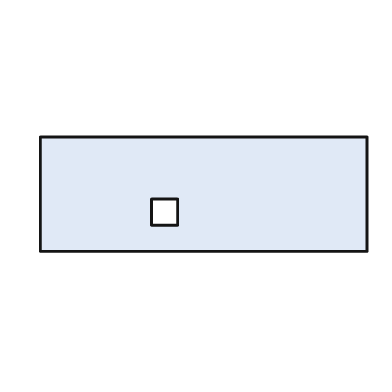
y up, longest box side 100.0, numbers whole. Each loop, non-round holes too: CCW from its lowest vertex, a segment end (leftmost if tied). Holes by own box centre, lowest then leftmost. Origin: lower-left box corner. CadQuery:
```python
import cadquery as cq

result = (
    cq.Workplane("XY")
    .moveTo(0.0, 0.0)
    .lineTo(100.0, 0.0)
    .lineTo(100.0, 35.0)
    .lineTo(0.0, 35.0)
    .close()
    .moveTo(34.0, 8.0)
    .lineTo(42.0, 8.0)
    .lineTo(42.0, 16.0)
    .lineTo(34.0, 16.0)
    .close()
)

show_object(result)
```